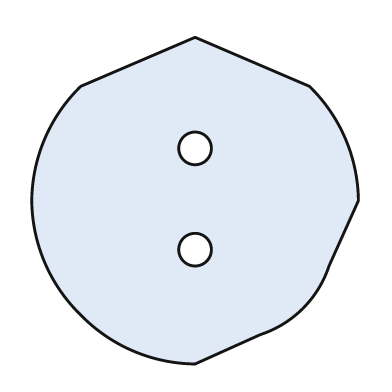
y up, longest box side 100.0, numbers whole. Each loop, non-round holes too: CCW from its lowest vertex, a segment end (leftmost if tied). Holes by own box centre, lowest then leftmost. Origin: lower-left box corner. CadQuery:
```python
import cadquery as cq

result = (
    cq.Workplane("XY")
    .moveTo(50.0, 0.0)
    .lineTo(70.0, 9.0)
    .threePointArc((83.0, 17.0), (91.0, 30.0))
    .lineTo(100.0, 50.0)
    .threePointArc((96.0, 69.0), (85.0, 85.0))
    .lineTo(50.0, 100.0)
    .lineTo(15.0, 85.0)
    .threePointArc((4.0, 69.0), (0.0, 50.0))
    .threePointArc((4.0, 31.0), (15.0, 15.0))
    .threePointArc((31.0, 4.0), (50.0, 0.0))
    .close()
    .moveTo(50.0, 35.0)
    .circle(5.0)
    .moveTo(50.0, 66.0)
    .circle(5.0)
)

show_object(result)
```